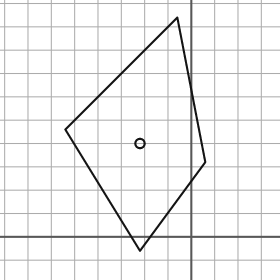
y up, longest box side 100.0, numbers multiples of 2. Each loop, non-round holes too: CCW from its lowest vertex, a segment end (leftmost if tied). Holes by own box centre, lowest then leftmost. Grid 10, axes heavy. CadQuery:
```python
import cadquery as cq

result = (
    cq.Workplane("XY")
    .moveTo(-22.0, -6.0)
    .lineTo(6.0, 32.0)
    .lineTo(-6.0, 94.0)
    .lineTo(-54.0, 46.0)
    .close()
    .moveTo(-22.0, 40.0)
    .circle(2.0)
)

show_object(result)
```